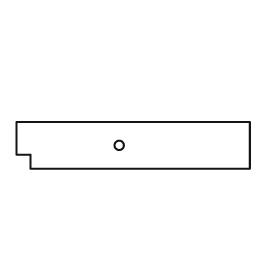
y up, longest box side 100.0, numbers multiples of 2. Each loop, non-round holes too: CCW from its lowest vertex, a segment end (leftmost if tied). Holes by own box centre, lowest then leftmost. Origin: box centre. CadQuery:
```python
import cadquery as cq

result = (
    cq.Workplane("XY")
    .moveTo(-44.0, -10.0)
    .lineTo(50.0, -10.0)
    .lineTo(50.0, 10.0)
    .lineTo(-50.0, 10.0)
    .lineTo(-50.0, -4.0)
    .lineTo(-44.0, -4.0)
    .close()
    .moveTo(-6.0, 0.0)
    .circle(2.0)
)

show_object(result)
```